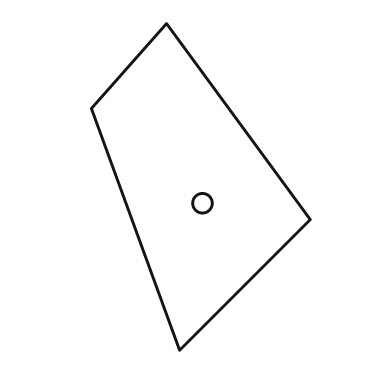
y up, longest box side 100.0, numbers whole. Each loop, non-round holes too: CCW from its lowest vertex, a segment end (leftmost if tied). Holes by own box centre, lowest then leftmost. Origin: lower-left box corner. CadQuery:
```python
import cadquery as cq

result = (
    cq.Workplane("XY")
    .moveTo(27.0, 0.0)
    .lineTo(67.0, 40.0)
    .lineTo(23.0, 100.0)
    .lineTo(0.0, 74.0)
    .close()
    .moveTo(34.0, 45.0)
    .circle(3.0)
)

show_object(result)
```